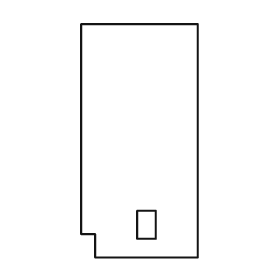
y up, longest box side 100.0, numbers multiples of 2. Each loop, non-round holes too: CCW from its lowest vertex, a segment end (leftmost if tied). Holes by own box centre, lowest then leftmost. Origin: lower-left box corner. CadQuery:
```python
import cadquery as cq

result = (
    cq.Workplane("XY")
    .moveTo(6.0, 0.0)
    .lineTo(50.0, 0.0)
    .lineTo(50.0, 100.0)
    .lineTo(0.0, 100.0)
    .lineTo(0.0, 10.0)
    .lineTo(6.0, 10.0)
    .close()
    .moveTo(24.0, 8.0)
    .lineTo(32.0, 8.0)
    .lineTo(32.0, 20.0)
    .lineTo(24.0, 20.0)
    .close()
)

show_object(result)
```